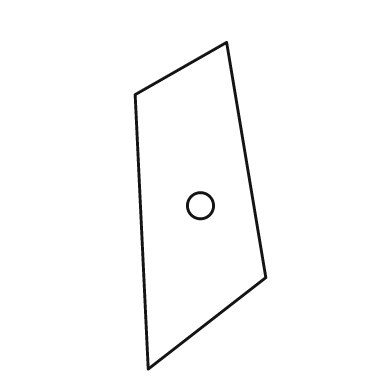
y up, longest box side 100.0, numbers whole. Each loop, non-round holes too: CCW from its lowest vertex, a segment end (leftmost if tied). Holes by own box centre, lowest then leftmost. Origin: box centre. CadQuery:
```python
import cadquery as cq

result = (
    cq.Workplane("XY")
    .moveTo(-16.0, -50.0)
    .lineTo(20.0, -22.0)
    .lineTo(8.0, 50.0)
    .lineTo(-20.0, 34.0)
    .close()
    .moveTo(0.0, 0.0)
    .circle(4.0)
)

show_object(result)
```